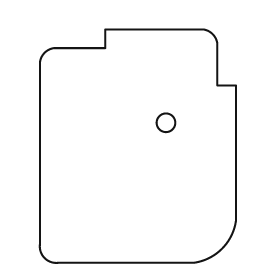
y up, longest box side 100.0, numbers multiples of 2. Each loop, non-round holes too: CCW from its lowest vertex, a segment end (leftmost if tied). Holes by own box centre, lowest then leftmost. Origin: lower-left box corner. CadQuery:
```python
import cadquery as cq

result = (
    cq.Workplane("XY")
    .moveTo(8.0, 0.0)
    .lineTo(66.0, 0.0)
    .threePointArc((78.0, 6.0), (84.0, 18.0))
    .lineTo(84.0, 76.0)
    .lineTo(76.0, 76.0)
    .lineTo(76.0, 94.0)
    .threePointArc((74.0, 98.0), (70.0, 100.0))
    .lineTo(28.0, 100.0)
    .lineTo(28.0, 92.0)
    .lineTo(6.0, 92.0)
    .threePointArc((2.0, 90.0), (0.0, 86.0))
    .lineTo(0.0, 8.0)
    .threePointArc((2.0, 2.0), (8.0, 0.0))
    .close()
    .moveTo(54.0, 60.0)
    .circle(4.0)
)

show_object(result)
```